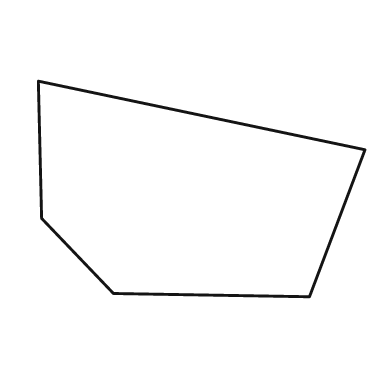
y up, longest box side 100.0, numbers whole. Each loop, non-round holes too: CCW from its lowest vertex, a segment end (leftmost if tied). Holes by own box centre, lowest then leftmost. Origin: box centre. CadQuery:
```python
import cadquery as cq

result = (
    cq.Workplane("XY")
    .moveTo(33.0, -33.0)
    .lineTo(50.0, 12.0)
    .lineTo(-50.0, 33.0)
    .lineTo(-49.0, -9.0)
    .lineTo(-27.0, -32.0)
    .close()
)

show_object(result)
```